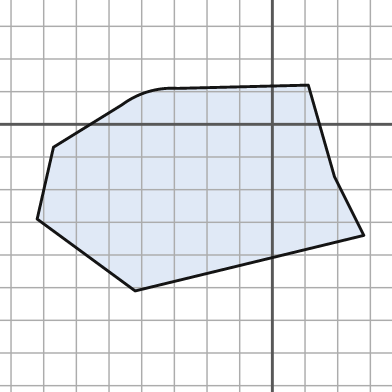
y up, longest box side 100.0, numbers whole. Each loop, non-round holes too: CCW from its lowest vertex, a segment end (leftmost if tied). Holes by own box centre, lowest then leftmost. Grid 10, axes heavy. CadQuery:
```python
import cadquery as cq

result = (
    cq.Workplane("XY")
    .moveTo(-42.0, -51.0)
    .lineTo(28.0, -34.0)
    .lineTo(19.0, -16.0)
    .lineTo(11.0, 12.0)
    .lineTo(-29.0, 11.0)
    .threePointArc((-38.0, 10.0), (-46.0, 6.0))
    .lineTo(-67.0, -7.0)
    .lineTo(-72.0, -29.0)
    .close()
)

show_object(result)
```